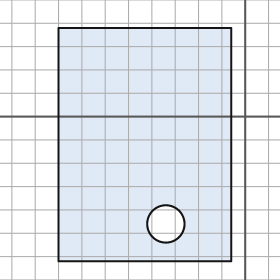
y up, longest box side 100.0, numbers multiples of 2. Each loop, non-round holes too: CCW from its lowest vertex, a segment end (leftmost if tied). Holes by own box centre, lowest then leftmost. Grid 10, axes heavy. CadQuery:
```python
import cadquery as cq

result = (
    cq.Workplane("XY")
    .moveTo(-80.0, -62.0)
    .lineTo(-6.0, -62.0)
    .lineTo(-6.0, 38.0)
    .lineTo(-80.0, 38.0)
    .close()
    .moveTo(-34.0, -46.0)
    .circle(8.0)
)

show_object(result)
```